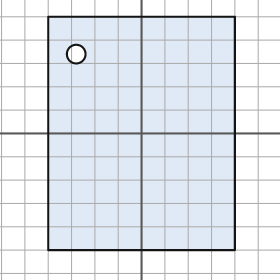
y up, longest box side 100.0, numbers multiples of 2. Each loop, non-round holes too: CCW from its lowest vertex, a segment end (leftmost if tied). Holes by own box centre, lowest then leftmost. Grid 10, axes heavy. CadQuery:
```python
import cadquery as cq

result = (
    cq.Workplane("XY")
    .moveTo(-40.0, -50.0)
    .lineTo(40.0, -50.0)
    .lineTo(40.0, 50.0)
    .lineTo(-40.0, 50.0)
    .close()
    .moveTo(-28.0, 34.0)
    .circle(4.0)
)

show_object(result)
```